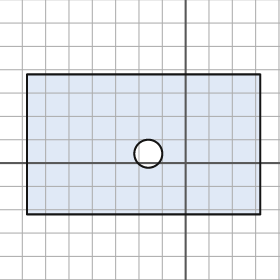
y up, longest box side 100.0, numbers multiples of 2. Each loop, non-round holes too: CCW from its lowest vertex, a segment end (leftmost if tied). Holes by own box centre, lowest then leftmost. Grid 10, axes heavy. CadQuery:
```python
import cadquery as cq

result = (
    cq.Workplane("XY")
    .moveTo(-68.0, -22.0)
    .lineTo(32.0, -22.0)
    .lineTo(32.0, 38.0)
    .lineTo(-68.0, 38.0)
    .close()
    .moveTo(-16.0, 4.0)
    .circle(6.0)
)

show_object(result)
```